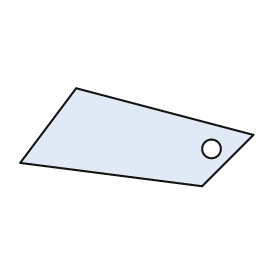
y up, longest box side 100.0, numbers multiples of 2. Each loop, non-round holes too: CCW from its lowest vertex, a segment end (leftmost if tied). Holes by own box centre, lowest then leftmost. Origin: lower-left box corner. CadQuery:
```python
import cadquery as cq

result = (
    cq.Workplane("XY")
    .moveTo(78.0, 0.0)
    .lineTo(100.0, 22.0)
    .lineTo(24.0, 42.0)
    .lineTo(0.0, 10.0)
    .close()
    .moveTo(82.0, 16.0)
    .circle(4.0)
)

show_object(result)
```